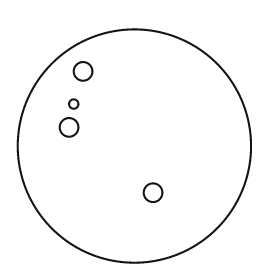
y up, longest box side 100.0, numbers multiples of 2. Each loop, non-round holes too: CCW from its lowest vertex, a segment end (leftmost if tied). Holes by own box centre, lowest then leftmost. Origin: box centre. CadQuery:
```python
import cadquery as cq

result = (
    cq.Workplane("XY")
    .moveTo(0.0, 0.0)
    .circle(50.0)
    .moveTo(8.0, -20.0)
    .circle(4.0)
    .moveTo(-28.0, 8.0)
    .circle(4.0)
    .moveTo(-26.0, 18.0)
    .circle(2.0)
    .moveTo(-22.0, 32.0)
    .circle(4.0)
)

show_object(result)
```